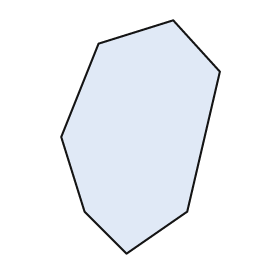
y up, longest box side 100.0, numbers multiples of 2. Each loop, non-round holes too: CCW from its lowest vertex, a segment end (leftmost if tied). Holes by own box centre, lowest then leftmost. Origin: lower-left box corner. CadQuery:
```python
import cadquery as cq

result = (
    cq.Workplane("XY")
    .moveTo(28.0, 0.0)
    .lineTo(54.0, 18.0)
    .lineTo(68.0, 78.0)
    .lineTo(48.0, 100.0)
    .lineTo(16.0, 90.0)
    .lineTo(0.0, 50.0)
    .lineTo(10.0, 18.0)
    .close()
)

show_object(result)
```